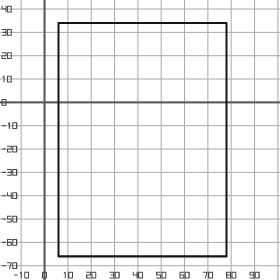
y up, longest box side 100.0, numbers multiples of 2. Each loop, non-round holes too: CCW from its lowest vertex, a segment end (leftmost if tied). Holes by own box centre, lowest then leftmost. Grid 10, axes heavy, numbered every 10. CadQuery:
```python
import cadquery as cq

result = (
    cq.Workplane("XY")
    .moveTo(6.0, -66.0)
    .lineTo(78.0, -66.0)
    .lineTo(78.0, 34.0)
    .lineTo(6.0, 34.0)
    .close()
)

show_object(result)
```